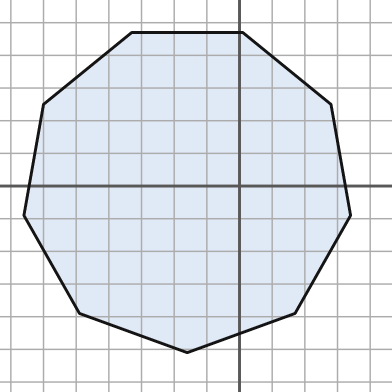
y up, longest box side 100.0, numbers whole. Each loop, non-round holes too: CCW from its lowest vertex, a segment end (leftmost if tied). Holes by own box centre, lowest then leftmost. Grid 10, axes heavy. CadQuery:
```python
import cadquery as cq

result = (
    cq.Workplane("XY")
    .moveTo(-16.0, -51.0)
    .lineTo(17.0, -39.0)
    .lineTo(34.0, -9.0)
    .lineTo(28.0, 25.0)
    .lineTo(1.0, 47.0)
    .lineTo(-33.0, 47.0)
    .lineTo(-60.0, 25.0)
    .lineTo(-66.0, -9.0)
    .lineTo(-49.0, -39.0)
    .close()
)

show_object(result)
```